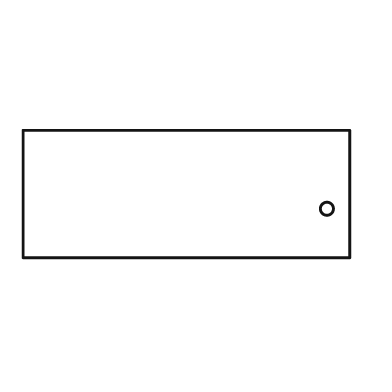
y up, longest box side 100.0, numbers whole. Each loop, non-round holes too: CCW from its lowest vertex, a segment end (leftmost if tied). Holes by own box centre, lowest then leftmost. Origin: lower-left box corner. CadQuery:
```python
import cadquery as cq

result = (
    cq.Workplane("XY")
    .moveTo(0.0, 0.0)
    .lineTo(100.0, 0.0)
    .lineTo(100.0, 39.0)
    .lineTo(0.0, 39.0)
    .close()
    .moveTo(93.0, 15.0)
    .circle(2.0)
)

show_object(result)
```